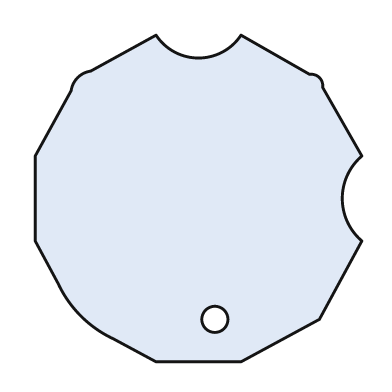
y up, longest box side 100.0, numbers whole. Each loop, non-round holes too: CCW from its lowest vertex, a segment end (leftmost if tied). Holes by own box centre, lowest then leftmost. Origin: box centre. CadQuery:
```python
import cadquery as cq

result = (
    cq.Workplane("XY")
    .moveTo(-13.0, -50.0)
    .lineTo(13.0, -50.0)
    .lineTo(37.0, -37.0)
    .lineTo(50.0, -13.0)
    .threePointArc((44.0, 0.0), (50.0, 13.0))
    .lineTo(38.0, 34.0)
    .threePointArc((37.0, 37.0), (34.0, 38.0))
    .lineTo(13.0, 50.0)
    .threePointArc((0.0, 43.0), (-13.0, 50.0))
    .lineTo(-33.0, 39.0)
    .threePointArc((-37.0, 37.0), (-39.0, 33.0))
    .lineTo(-50.0, 13.0)
    .lineTo(-50.0, -13.0)
    .lineTo(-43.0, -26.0)
    .threePointArc((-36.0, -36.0), (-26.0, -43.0))
    .close()
    .moveTo(5.0, -37.0)
    .circle(4.0)
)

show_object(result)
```